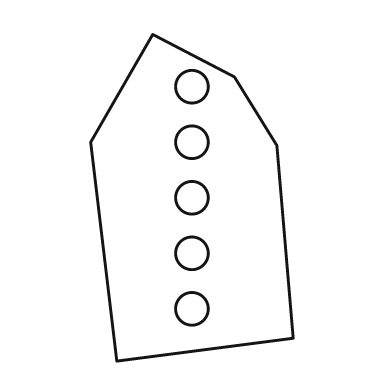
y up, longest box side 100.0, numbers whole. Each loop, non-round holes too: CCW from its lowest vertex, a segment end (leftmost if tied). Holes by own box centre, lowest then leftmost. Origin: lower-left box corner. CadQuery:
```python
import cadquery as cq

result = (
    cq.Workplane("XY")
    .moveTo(8.0, 0.0)
    .lineTo(62.0, 7.0)
    .lineTo(57.0, 66.0)
    .lineTo(44.0, 87.0)
    .lineTo(19.0, 100.0)
    .lineTo(0.0, 67.0)
    .close()
    .moveTo(31.0, 16.0)
    .circle(5.0)
    .moveTo(31.0, 33.0)
    .circle(5.0)
    .moveTo(31.0, 50.0)
    .circle(5.0)
    .moveTo(31.0, 67.0)
    .circle(5.0)
    .moveTo(31.0, 84.0)
    .circle(5.0)
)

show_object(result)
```